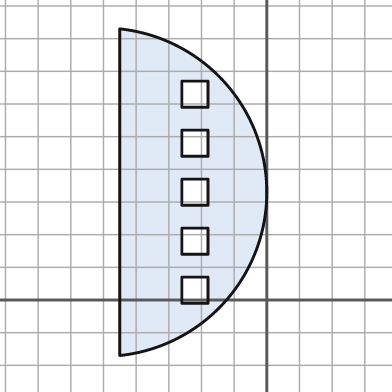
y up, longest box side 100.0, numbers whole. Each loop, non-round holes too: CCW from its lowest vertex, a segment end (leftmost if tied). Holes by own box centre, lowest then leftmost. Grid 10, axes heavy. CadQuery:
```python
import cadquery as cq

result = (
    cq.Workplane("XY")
    .moveTo(-45.0, -17.0)
    .threePointArc((0.0, 33.0), (-45.0, 83.0))
    .close()
    .moveTo(-26.0, -1.0)
    .lineTo(-18.0, -1.0)
    .lineTo(-18.0, 7.0)
    .lineTo(-26.0, 7.0)
    .close()
    .moveTo(-26.0, 14.0)
    .lineTo(-18.0, 14.0)
    .lineTo(-18.0, 22.0)
    .lineTo(-26.0, 22.0)
    .close()
    .moveTo(-26.0, 29.0)
    .lineTo(-18.0, 29.0)
    .lineTo(-18.0, 37.0)
    .lineTo(-26.0, 37.0)
    .close()
    .moveTo(-26.0, 44.0)
    .lineTo(-18.0, 44.0)
    .lineTo(-18.0, 52.0)
    .lineTo(-26.0, 52.0)
    .close()
    .moveTo(-26.0, 59.0)
    .lineTo(-18.0, 59.0)
    .lineTo(-18.0, 67.0)
    .lineTo(-26.0, 67.0)
    .close()
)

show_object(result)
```